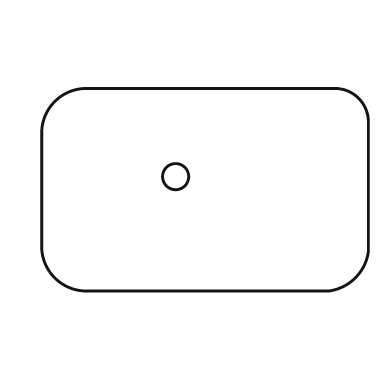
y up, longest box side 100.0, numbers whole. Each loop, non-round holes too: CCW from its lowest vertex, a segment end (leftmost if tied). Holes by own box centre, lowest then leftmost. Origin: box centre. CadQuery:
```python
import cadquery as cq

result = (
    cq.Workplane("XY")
    .moveTo(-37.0, -31.0)
    .lineTo(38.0, -31.0)
    .threePointArc((46.0, -27.0), (50.0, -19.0))
    .lineTo(50.0, 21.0)
    .threePointArc((47.0, 28.0), (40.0, 31.0))
    .lineTo(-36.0, 31.0)
    .threePointArc((-46.0, 27.0), (-50.0, 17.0))
    .lineTo(-50.0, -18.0)
    .threePointArc((-46.0, -27.0), (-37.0, -31.0))
    .close()
    .moveTo(-9.0, 4.0)
    .circle(4.0)
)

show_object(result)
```